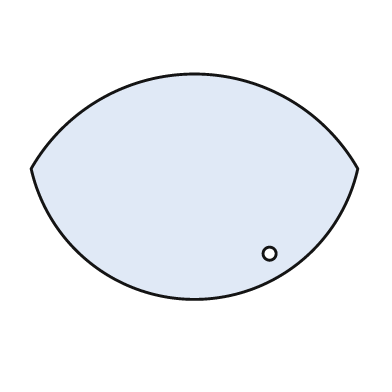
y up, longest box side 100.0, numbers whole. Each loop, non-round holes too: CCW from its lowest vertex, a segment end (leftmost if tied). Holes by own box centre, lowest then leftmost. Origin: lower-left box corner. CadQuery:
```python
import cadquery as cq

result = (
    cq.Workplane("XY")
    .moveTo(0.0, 40.0)
    .threePointArc((50.0, 0.0), (100.0, 40.0))
    .threePointArc((50.0, 69.0), (0.0, 40.0))
    .close()
    .moveTo(73.0, 14.0)
    .circle(2.0)
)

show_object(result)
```